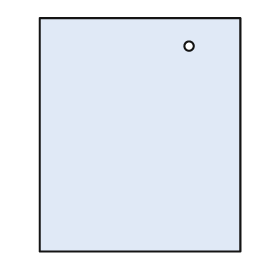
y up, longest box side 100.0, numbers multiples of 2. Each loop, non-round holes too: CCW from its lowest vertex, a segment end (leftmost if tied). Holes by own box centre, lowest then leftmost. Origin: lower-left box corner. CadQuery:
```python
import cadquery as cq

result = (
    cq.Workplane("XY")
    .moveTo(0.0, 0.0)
    .lineTo(86.0, 0.0)
    .lineTo(86.0, 100.0)
    .lineTo(0.0, 100.0)
    .close()
    .moveTo(64.0, 88.0)
    .circle(2.0)
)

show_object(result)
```